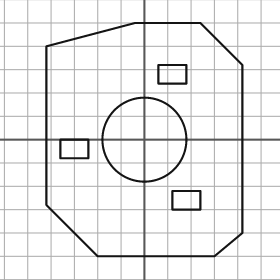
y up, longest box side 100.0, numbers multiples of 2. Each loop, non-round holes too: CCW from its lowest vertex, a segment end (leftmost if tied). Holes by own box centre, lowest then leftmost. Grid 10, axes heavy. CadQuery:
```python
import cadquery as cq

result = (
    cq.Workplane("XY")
    .moveTo(-20.0, -50.0)
    .lineTo(30.0, -50.0)
    .lineTo(42.0, -40.0)
    .lineTo(42.0, 32.0)
    .lineTo(24.0, 50.0)
    .lineTo(-4.0, 50.0)
    .lineTo(-42.0, 40.0)
    .lineTo(-42.0, -28.0)
    .close()
    .moveTo(12.0, -30.0)
    .lineTo(24.0, -30.0)
    .lineTo(24.0, -22.0)
    .lineTo(12.0, -22.0)
    .close()
    .moveTo(-36.0, -8.0)
    .lineTo(-24.0, -8.0)
    .lineTo(-24.0, 0.0)
    .lineTo(-36.0, 0.0)
    .close()
    .moveTo(0.0, 0.0)
    .circle(18.0)
    .moveTo(6.0, 24.0)
    .lineTo(18.0, 24.0)
    .lineTo(18.0, 32.0)
    .lineTo(6.0, 32.0)
    .close()
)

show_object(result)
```